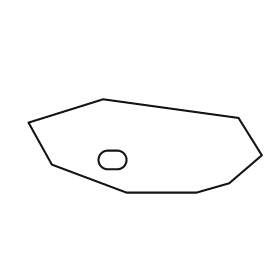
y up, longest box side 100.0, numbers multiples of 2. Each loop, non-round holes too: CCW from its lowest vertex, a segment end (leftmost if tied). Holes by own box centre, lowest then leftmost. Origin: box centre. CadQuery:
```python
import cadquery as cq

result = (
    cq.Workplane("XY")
    .moveTo(-8.0, -20.0)
    .lineTo(22.0, -20.0)
    .lineTo(36.0, -16.0)
    .lineTo(50.0, -4.0)
    .lineTo(40.0, 12.0)
    .lineTo(-18.0, 20.0)
    .lineTo(-50.0, 10.0)
    .lineTo(-40.0, -8.0)
    .close()
    .moveTo(-16.0, -10.0)
    .lineTo(-12.0, -10.0)
    .threePointArc((-8.0, -6.0), (-12.0, -2.0))
    .lineTo(-16.0, -2.0)
    .threePointArc((-20.0, -6.0), (-16.0, -10.0))
    .close()
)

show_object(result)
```